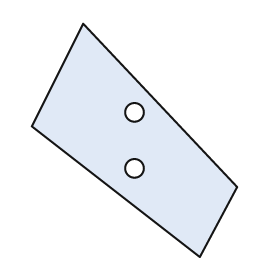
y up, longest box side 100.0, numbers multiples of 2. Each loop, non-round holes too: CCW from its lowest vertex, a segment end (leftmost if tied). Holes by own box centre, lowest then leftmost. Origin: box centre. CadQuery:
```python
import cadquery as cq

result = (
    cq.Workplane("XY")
    .moveTo(28.0, -50.0)
    .lineTo(44.0, -20.0)
    .lineTo(-22.0, 50.0)
    .lineTo(-44.0, 6.0)
    .close()
    .moveTo(0.0, -12.0)
    .circle(4.0)
    .moveTo(0.0, 12.0)
    .circle(4.0)
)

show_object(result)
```